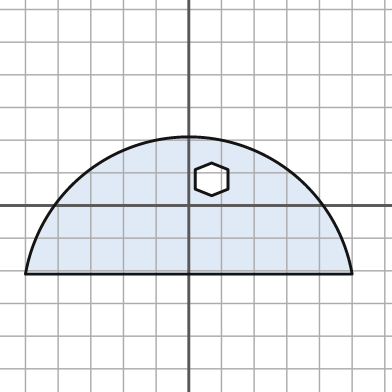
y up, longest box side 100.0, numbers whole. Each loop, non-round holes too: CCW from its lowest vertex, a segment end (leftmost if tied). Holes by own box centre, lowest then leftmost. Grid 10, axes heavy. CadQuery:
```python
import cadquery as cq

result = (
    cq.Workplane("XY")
    .moveTo(-50.0, -21.0)
    .lineTo(50.0, -21.0)
    .threePointArc((0.0, 21.0), (-50.0, -21.0))
    .close()
    .moveTo(7.0, 3.0)
    .lineTo(12.0, 5.0)
    .lineTo(12.0, 11.0)
    .lineTo(7.0, 13.0)
    .lineTo(2.0, 11.0)
    .lineTo(2.0, 5.0)
    .close()
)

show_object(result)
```